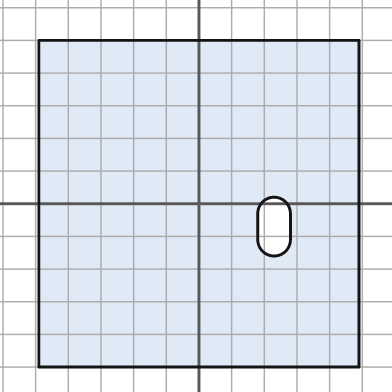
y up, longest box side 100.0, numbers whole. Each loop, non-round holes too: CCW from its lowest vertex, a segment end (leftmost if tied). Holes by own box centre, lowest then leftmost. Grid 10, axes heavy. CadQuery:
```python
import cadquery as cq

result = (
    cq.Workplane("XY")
    .moveTo(-49.0, -50.0)
    .lineTo(49.0, -50.0)
    .lineTo(49.0, 50.0)
    .lineTo(-49.0, 50.0)
    .close()
    .moveTo(18.0, -11.0)
    .threePointArc((23.0, -16.0), (28.0, -11.0))
    .lineTo(28.0, -3.0)
    .threePointArc((23.0, 2.0), (18.0, -3.0))
    .close()
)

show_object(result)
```